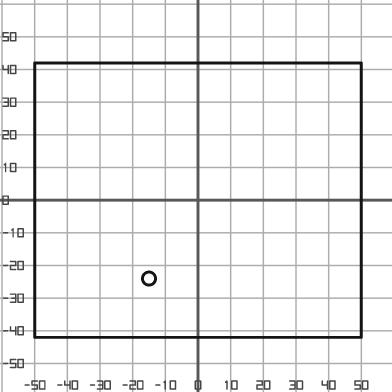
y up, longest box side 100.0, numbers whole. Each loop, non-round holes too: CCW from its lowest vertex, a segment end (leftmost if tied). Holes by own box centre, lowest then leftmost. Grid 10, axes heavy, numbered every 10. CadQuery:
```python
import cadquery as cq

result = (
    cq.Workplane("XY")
    .moveTo(-50.0, -42.0)
    .lineTo(50.0, -42.0)
    .lineTo(50.0, 42.0)
    .lineTo(-50.0, 42.0)
    .close()
    .moveTo(-15.0, -24.0)
    .circle(2.0)
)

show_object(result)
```